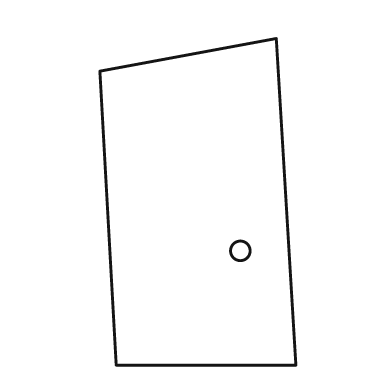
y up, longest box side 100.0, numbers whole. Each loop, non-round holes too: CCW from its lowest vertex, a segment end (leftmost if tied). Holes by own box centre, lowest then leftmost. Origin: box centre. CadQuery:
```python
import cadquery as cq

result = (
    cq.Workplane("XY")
    .moveTo(-25.0, -50.0)
    .lineTo(30.0, -50.0)
    .lineTo(24.0, 50.0)
    .lineTo(-30.0, 40.0)
    .close()
    .moveTo(13.0, -15.0)
    .circle(3.0)
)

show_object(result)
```